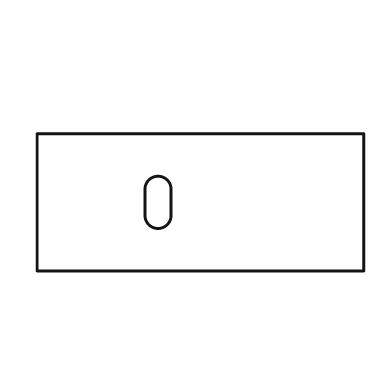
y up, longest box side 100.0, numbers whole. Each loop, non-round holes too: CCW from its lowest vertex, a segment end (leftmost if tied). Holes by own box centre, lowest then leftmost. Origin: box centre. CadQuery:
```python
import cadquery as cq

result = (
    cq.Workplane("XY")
    .moveTo(-50.0, -21.0)
    .lineTo(50.0, -21.0)
    .lineTo(50.0, 21.0)
    .lineTo(-50.0, 21.0)
    .close()
    .moveTo(-17.0, -4.0)
    .threePointArc((-13.0, -8.0), (-9.0, -4.0))
    .lineTo(-9.0, 4.0)
    .threePointArc((-13.0, 8.0), (-17.0, 4.0))
    .close()
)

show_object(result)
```